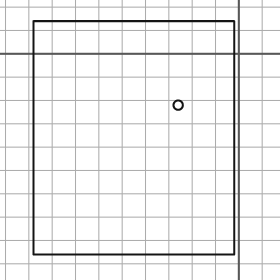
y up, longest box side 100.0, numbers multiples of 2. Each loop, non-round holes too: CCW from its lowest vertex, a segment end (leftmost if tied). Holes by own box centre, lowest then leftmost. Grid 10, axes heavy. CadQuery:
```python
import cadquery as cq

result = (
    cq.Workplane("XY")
    .moveTo(-88.0, -86.0)
    .lineTo(-2.0, -86.0)
    .lineTo(-2.0, 14.0)
    .lineTo(-88.0, 14.0)
    .close()
    .moveTo(-26.0, -22.0)
    .circle(2.0)
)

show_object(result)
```